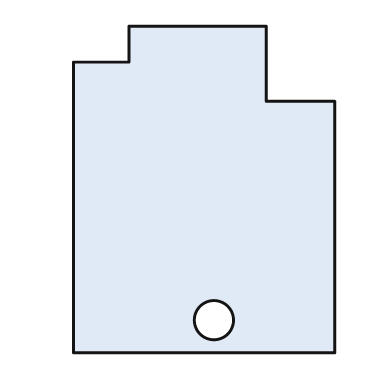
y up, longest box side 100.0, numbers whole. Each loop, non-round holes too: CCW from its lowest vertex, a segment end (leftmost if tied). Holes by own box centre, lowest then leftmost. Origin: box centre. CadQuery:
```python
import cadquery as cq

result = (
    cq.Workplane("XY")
    .moveTo(-40.0, -50.0)
    .lineTo(40.0, -50.0)
    .lineTo(40.0, 27.0)
    .lineTo(19.0, 27.0)
    .lineTo(19.0, 50.0)
    .lineTo(-23.0, 50.0)
    .lineTo(-23.0, 39.0)
    .lineTo(-40.0, 39.0)
    .close()
    .moveTo(3.0, -40.0)
    .circle(6.0)
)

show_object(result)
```